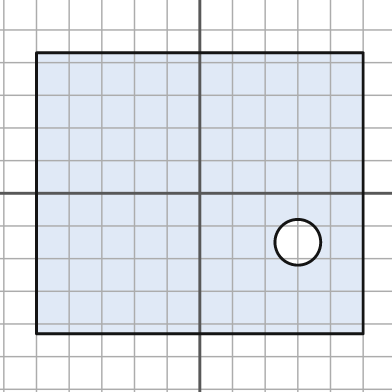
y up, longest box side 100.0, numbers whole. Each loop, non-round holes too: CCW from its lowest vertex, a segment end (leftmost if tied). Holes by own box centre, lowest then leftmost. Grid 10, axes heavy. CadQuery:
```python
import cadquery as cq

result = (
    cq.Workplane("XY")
    .moveTo(-50.0, -43.0)
    .lineTo(50.0, -43.0)
    .lineTo(50.0, 43.0)
    .lineTo(-50.0, 43.0)
    .close()
    .moveTo(30.0, -15.0)
    .circle(7.0)
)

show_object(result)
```